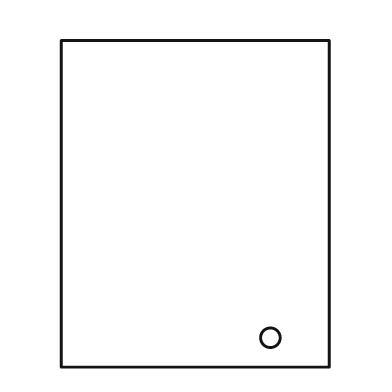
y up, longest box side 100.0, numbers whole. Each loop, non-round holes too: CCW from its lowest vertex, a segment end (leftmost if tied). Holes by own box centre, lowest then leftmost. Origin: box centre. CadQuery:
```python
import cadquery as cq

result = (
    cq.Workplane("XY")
    .moveTo(-41.0, -50.0)
    .lineTo(41.0, -50.0)
    .lineTo(41.0, 50.0)
    .lineTo(-41.0, 50.0)
    .close()
    .moveTo(23.0, -41.0)
    .circle(3.0)
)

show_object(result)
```